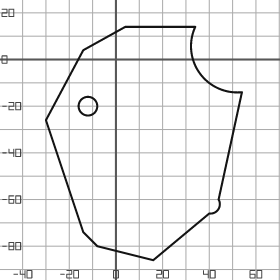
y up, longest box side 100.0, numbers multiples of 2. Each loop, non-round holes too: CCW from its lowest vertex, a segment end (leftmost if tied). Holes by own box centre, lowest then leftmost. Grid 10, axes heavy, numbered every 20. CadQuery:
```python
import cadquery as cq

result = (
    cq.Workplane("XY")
    .moveTo(16.0, -86.0)
    .lineTo(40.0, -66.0)
    .threePointArc((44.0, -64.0), (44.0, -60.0))
    .lineTo(54.0, -14.0)
    .threePointArc((36.0, -6.0), (34.0, 14.0))
    .lineTo(4.0, 14.0)
    .lineTo(-14.0, 4.0)
    .lineTo(-30.0, -26.0)
    .lineTo(-14.0, -74.0)
    .lineTo(-8.0, -80.0)
    .close()
    .moveTo(-12.0, -20.0)
    .circle(4.0)
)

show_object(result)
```